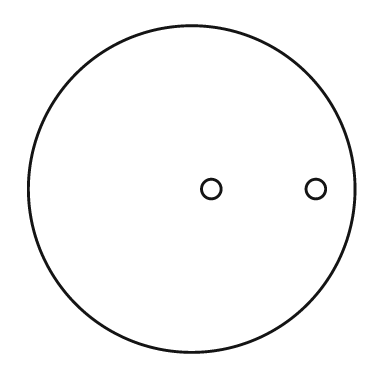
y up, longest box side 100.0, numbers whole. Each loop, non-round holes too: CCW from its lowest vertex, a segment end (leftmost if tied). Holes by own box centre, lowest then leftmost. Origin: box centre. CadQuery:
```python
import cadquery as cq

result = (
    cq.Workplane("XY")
    .moveTo(0.0, 0.0)
    .circle(50.0)
    .moveTo(6.0, 0.0)
    .circle(3.0)
    .moveTo(38.0, 0.0)
    .circle(3.0)
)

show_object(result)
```